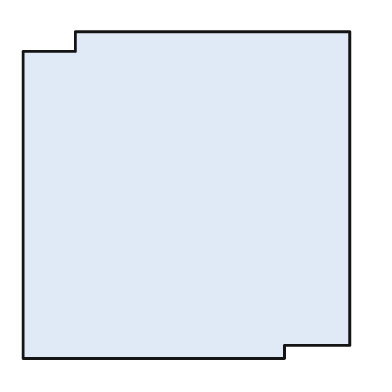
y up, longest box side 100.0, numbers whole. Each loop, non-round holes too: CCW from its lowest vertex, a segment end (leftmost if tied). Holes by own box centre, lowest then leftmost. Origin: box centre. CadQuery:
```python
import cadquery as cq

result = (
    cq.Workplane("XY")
    .moveTo(-50.0, -50.0)
    .lineTo(30.0, -50.0)
    .lineTo(30.0, -46.0)
    .lineTo(50.0, -46.0)
    .lineTo(50.0, 50.0)
    .lineTo(-34.0, 50.0)
    .lineTo(-34.0, 44.0)
    .lineTo(-50.0, 44.0)
    .close()
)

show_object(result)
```